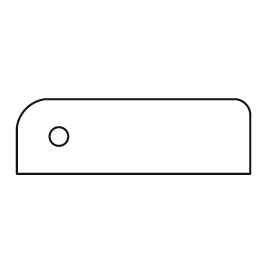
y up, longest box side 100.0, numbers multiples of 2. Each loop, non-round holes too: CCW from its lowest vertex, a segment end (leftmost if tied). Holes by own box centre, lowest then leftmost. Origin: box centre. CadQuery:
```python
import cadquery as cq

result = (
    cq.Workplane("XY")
    .moveTo(-50.0, -16.0)
    .lineTo(50.0, -16.0)
    .lineTo(50.0, 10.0)
    .threePointArc((48.0, 14.0), (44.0, 16.0))
    .lineTo(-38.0, 16.0)
    .threePointArc((-46.0, 12.0), (-50.0, 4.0))
    .close()
    .moveTo(-32.0, 0.0)
    .circle(4.0)
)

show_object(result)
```